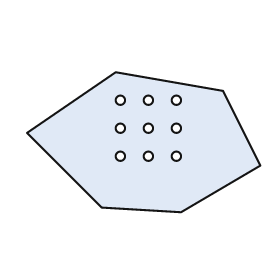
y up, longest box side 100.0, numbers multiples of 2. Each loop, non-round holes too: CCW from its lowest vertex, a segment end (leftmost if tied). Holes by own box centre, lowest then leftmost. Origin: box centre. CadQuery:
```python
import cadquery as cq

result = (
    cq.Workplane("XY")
    .moveTo(16.0, -30.0)
    .lineTo(50.0, -10.0)
    .lineTo(34.0, 22.0)
    .lineTo(-12.0, 30.0)
    .lineTo(-50.0, 4.0)
    .lineTo(-18.0, -28.0)
    .close()
    .moveTo(-10.0, -6.0)
    .circle(2.0)
    .moveTo(2.0, -6.0)
    .circle(2.0)
    .moveTo(14.0, -6.0)
    .circle(2.0)
    .moveTo(-10.0, 6.0)
    .circle(2.0)
    .moveTo(2.0, 6.0)
    .circle(2.0)
    .moveTo(14.0, 6.0)
    .circle(2.0)
    .moveTo(-10.0, 18.0)
    .circle(2.0)
    .moveTo(2.0, 18.0)
    .circle(2.0)
    .moveTo(14.0, 18.0)
    .circle(2.0)
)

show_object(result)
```